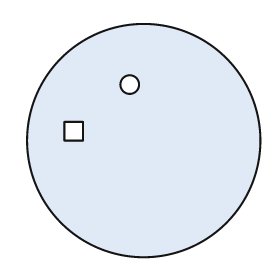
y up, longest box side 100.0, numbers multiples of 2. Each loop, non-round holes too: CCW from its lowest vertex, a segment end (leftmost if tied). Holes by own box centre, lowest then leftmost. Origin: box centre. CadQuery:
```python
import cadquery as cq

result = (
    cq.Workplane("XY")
    .moveTo(0.0, 0.0)
    .circle(50.0)
    .moveTo(-34.0, 0.0)
    .lineTo(-26.0, 0.0)
    .lineTo(-26.0, 8.0)
    .lineTo(-34.0, 8.0)
    .close()
    .moveTo(-6.0, 24.0)
    .circle(4.0)
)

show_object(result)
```